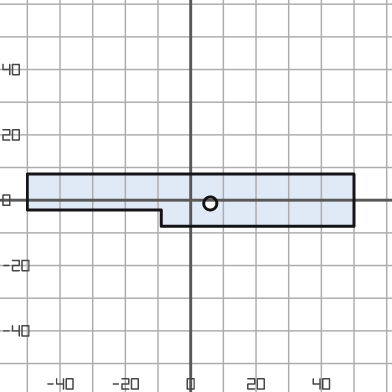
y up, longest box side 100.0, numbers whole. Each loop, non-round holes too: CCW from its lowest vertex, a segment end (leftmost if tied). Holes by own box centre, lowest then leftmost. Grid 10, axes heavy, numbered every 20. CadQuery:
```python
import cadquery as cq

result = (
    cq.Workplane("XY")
    .moveTo(-9.0, -8.0)
    .lineTo(50.0, -8.0)
    .lineTo(50.0, 8.0)
    .lineTo(-50.0, 8.0)
    .lineTo(-50.0, -3.0)
    .lineTo(-9.0, -3.0)
    .close()
    .moveTo(6.0, -1.0)
    .circle(2.0)
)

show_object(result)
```